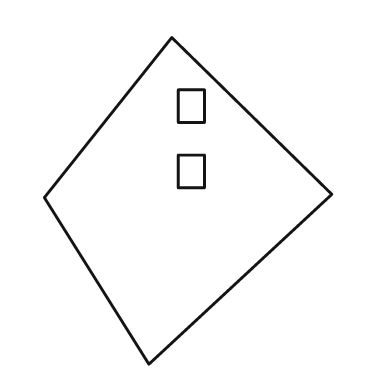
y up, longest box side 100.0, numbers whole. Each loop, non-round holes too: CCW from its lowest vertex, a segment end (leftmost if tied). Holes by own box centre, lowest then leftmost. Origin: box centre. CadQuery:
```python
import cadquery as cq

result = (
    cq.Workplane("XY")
    .moveTo(-12.0, -50.0)
    .lineTo(44.0, 2.0)
    .lineTo(-5.0, 50.0)
    .lineTo(-44.0, 1.0)
    .close()
    .moveTo(-3.0, 4.0)
    .lineTo(5.0, 4.0)
    .lineTo(5.0, 14.0)
    .lineTo(-3.0, 14.0)
    .close()
    .moveTo(-3.0, 24.0)
    .lineTo(5.0, 24.0)
    .lineTo(5.0, 34.0)
    .lineTo(-3.0, 34.0)
    .close()
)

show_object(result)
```